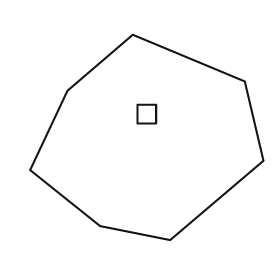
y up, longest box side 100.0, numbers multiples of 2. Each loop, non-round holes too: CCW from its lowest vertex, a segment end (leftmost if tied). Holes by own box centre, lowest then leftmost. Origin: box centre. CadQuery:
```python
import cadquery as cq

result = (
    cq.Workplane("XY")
    .moveTo(10.0, -44.0)
    .lineTo(50.0, -10.0)
    .lineTo(42.0, 24.0)
    .lineTo(-6.0, 44.0)
    .lineTo(-34.0, 20.0)
    .lineTo(-50.0, -14.0)
    .lineTo(-20.0, -38.0)
    .close()
    .moveTo(-4.0, 6.0)
    .lineTo(4.0, 6.0)
    .lineTo(4.0, 14.0)
    .lineTo(-4.0, 14.0)
    .close()
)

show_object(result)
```